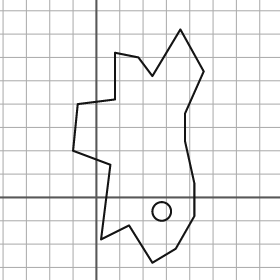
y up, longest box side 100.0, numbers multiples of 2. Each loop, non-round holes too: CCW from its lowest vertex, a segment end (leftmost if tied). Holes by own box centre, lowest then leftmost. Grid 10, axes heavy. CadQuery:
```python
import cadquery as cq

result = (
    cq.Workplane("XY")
    .moveTo(24.0, -28.0)
    .lineTo(34.0, -22.0)
    .lineTo(42.0, -8.0)
    .lineTo(42.0, 6.0)
    .lineTo(38.0, 24.0)
    .lineTo(38.0, 36.0)
    .lineTo(46.0, 54.0)
    .lineTo(36.0, 72.0)
    .lineTo(24.0, 52.0)
    .lineTo(18.0, 60.0)
    .lineTo(8.0, 62.0)
    .lineTo(8.0, 42.0)
    .lineTo(-8.0, 40.0)
    .lineTo(-10.0, 20.0)
    .lineTo(6.0, 14.0)
    .lineTo(2.0, -18.0)
    .lineTo(14.0, -12.0)
    .close()
    .moveTo(28.0, -6.0)
    .circle(4.0)
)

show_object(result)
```